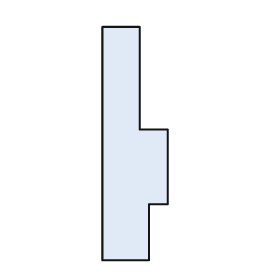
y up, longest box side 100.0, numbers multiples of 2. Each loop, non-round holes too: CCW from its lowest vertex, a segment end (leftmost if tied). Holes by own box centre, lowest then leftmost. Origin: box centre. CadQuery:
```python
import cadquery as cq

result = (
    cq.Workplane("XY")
    .moveTo(-14.0, -50.0)
    .lineTo(6.0, -50.0)
    .lineTo(6.0, -26.0)
    .lineTo(14.0, -26.0)
    .lineTo(14.0, 6.0)
    .lineTo(2.0, 6.0)
    .lineTo(2.0, 50.0)
    .lineTo(-14.0, 50.0)
    .close()
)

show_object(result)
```